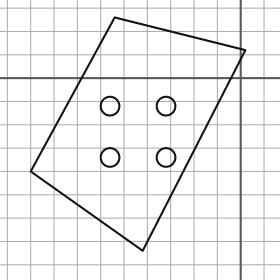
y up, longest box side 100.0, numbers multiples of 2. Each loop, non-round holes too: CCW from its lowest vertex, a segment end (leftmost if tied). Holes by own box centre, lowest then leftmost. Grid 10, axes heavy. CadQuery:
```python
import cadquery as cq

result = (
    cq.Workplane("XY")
    .moveTo(-42.0, -74.0)
    .lineTo(2.0, 12.0)
    .lineTo(-54.0, 26.0)
    .lineTo(-90.0, -40.0)
    .close()
    .moveTo(-56.0, -34.0)
    .circle(4.0)
    .moveTo(-32.0, -34.0)
    .circle(4.0)
    .moveTo(-56.0, -12.0)
    .circle(4.0)
    .moveTo(-32.0, -12.0)
    .circle(4.0)
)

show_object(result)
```